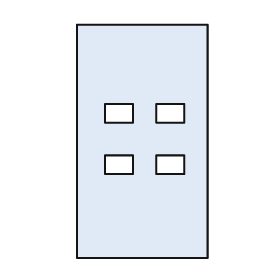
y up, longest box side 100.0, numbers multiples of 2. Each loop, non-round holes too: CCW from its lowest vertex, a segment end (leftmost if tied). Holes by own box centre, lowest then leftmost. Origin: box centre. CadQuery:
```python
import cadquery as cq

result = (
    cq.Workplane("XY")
    .moveTo(-28.0, -50.0)
    .lineTo(28.0, -50.0)
    .lineTo(28.0, 50.0)
    .lineTo(-28.0, 50.0)
    .close()
    .moveTo(-16.0, -14.0)
    .lineTo(-4.0, -14.0)
    .lineTo(-4.0, -6.0)
    .lineTo(-16.0, -6.0)
    .close()
    .moveTo(6.0, -14.0)
    .lineTo(18.0, -14.0)
    .lineTo(18.0, -6.0)
    .lineTo(6.0, -6.0)
    .close()
    .moveTo(-16.0, 8.0)
    .lineTo(-4.0, 8.0)
    .lineTo(-4.0, 16.0)
    .lineTo(-16.0, 16.0)
    .close()
    .moveTo(6.0, 8.0)
    .lineTo(18.0, 8.0)
    .lineTo(18.0, 16.0)
    .lineTo(6.0, 16.0)
    .close()
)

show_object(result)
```